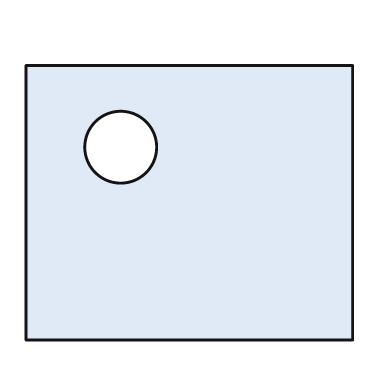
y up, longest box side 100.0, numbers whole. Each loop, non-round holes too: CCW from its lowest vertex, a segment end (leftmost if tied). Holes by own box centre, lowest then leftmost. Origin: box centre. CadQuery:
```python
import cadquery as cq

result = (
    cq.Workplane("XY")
    .moveTo(-50.0, -42.0)
    .lineTo(50.0, -42.0)
    .lineTo(50.0, 42.0)
    .lineTo(-50.0, 42.0)
    .close()
    .moveTo(-21.0, 17.0)
    .circle(11.0)
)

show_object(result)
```